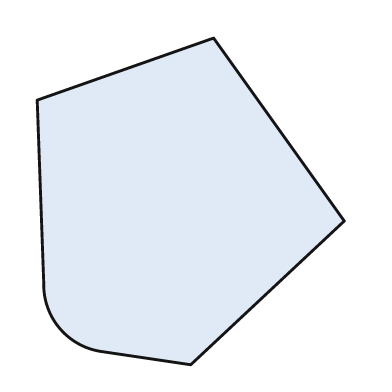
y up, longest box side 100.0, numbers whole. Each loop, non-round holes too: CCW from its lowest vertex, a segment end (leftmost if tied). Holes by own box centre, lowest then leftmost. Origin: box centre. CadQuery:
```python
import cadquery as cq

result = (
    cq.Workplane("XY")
    .moveTo(0.0, -50.0)
    .lineTo(47.0, -6.0)
    .lineTo(7.0, 50.0)
    .lineTo(-47.0, 31.0)
    .lineTo(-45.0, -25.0)
    .threePointArc((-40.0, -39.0), (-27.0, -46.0))
    .close()
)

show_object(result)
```